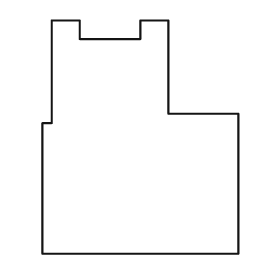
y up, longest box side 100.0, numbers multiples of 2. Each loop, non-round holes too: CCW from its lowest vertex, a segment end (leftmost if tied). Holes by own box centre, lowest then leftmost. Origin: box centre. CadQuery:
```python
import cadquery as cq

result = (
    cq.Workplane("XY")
    .moveTo(-42.0, -50.0)
    .lineTo(42.0, -50.0)
    .lineTo(42.0, 10.0)
    .lineTo(12.0, 10.0)
    .lineTo(12.0, 50.0)
    .lineTo(0.0, 50.0)
    .lineTo(0.0, 42.0)
    .lineTo(-26.0, 42.0)
    .lineTo(-26.0, 50.0)
    .lineTo(-38.0, 50.0)
    .lineTo(-38.0, 6.0)
    .lineTo(-42.0, 6.0)
    .close()
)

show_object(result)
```